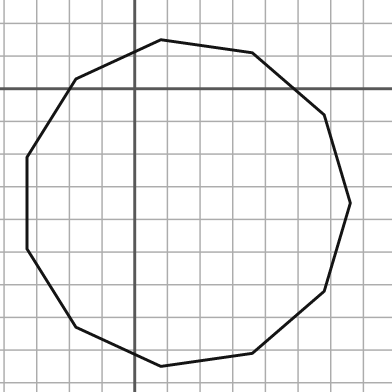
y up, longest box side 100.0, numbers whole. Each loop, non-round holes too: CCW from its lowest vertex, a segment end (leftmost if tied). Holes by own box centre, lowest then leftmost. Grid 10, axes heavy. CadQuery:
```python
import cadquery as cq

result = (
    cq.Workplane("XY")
    .moveTo(8.0, -85.0)
    .lineTo(36.0, -81.0)
    .lineTo(58.0, -62.0)
    .lineTo(66.0, -35.0)
    .lineTo(58.0, -8.0)
    .lineTo(36.0, 11.0)
    .lineTo(8.0, 15.0)
    .lineTo(-18.0, 3.0)
    .lineTo(-33.0, -21.0)
    .lineTo(-33.0, -49.0)
    .lineTo(-18.0, -73.0)
    .close()
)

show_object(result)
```